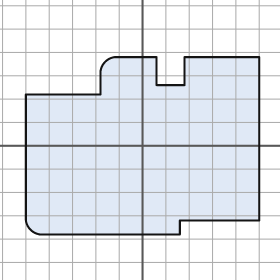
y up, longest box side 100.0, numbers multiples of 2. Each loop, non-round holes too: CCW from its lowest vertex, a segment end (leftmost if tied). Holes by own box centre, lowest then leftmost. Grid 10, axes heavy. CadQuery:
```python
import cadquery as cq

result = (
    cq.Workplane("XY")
    .moveTo(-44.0, -38.0)
    .lineTo(16.0, -38.0)
    .lineTo(16.0, -32.0)
    .lineTo(50.0, -32.0)
    .lineTo(50.0, 38.0)
    .lineTo(18.0, 38.0)
    .lineTo(18.0, 26.0)
    .lineTo(6.0, 26.0)
    .lineTo(6.0, 38.0)
    .lineTo(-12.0, 38.0)
    .threePointArc((-16.0, 36.0), (-18.0, 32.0))
    .lineTo(-18.0, 22.0)
    .lineTo(-50.0, 22.0)
    .lineTo(-50.0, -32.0)
    .threePointArc((-48.0, -36.0), (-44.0, -38.0))
    .close()
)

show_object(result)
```